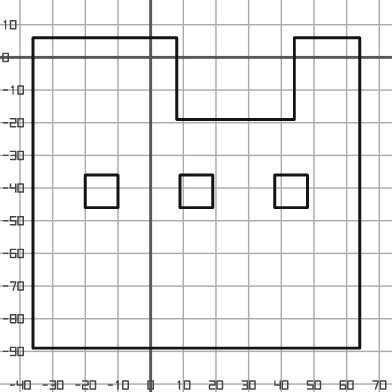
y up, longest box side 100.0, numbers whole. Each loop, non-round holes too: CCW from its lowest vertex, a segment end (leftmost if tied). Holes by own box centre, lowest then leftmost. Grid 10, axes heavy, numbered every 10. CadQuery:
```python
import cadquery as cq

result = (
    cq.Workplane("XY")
    .moveTo(-36.0, -89.0)
    .lineTo(64.0, -89.0)
    .lineTo(64.0, 6.0)
    .lineTo(44.0, 6.0)
    .lineTo(44.0, -19.0)
    .lineTo(8.0, -19.0)
    .lineTo(8.0, 6.0)
    .lineTo(-36.0, 6.0)
    .close()
    .moveTo(-20.0, -46.0)
    .lineTo(-10.0, -46.0)
    .lineTo(-10.0, -36.0)
    .lineTo(-20.0, -36.0)
    .close()
    .moveTo(9.0, -46.0)
    .lineTo(19.0, -46.0)
    .lineTo(19.0, -36.0)
    .lineTo(9.0, -36.0)
    .close()
    .moveTo(38.0, -46.0)
    .lineTo(48.0, -46.0)
    .lineTo(48.0, -36.0)
    .lineTo(38.0, -36.0)
    .close()
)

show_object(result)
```